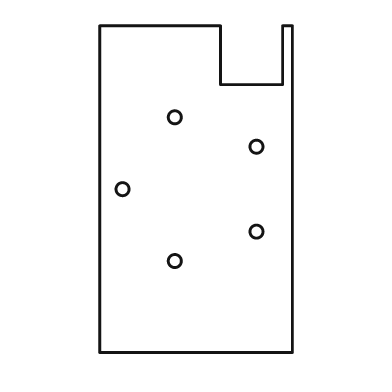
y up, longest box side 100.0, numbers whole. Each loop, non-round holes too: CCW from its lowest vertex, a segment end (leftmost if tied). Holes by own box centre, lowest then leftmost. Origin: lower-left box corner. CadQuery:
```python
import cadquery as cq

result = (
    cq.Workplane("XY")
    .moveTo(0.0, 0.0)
    .lineTo(59.0, 0.0)
    .lineTo(59.0, 100.0)
    .lineTo(56.0, 100.0)
    .lineTo(56.0, 82.0)
    .lineTo(37.0, 82.0)
    .lineTo(37.0, 100.0)
    .lineTo(0.0, 100.0)
    .close()
    .moveTo(23.0, 28.0)
    .circle(2.0)
    .moveTo(48.0, 37.0)
    .circle(2.0)
    .moveTo(7.0, 50.0)
    .circle(2.0)
    .moveTo(48.0, 63.0)
    .circle(2.0)
    .moveTo(23.0, 72.0)
    .circle(2.0)
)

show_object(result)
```